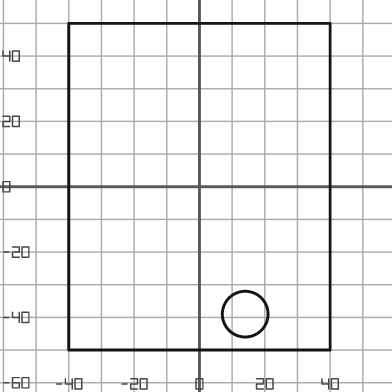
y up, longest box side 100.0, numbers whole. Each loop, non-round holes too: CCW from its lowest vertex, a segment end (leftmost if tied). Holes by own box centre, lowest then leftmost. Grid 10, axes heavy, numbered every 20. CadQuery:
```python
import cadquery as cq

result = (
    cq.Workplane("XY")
    .moveTo(-40.0, -50.0)
    .lineTo(40.0, -50.0)
    .lineTo(40.0, 50.0)
    .lineTo(-40.0, 50.0)
    .close()
    .moveTo(14.0, -39.0)
    .circle(7.0)
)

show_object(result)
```